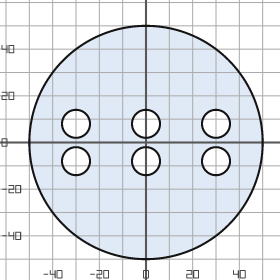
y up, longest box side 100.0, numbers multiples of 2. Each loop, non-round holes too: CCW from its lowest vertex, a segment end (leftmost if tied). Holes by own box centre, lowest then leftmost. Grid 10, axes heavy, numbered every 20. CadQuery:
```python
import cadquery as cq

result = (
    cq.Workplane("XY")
    .moveTo(0.0, 0.0)
    .circle(50.0)
    .moveTo(-30.0, -8.0)
    .circle(6.0)
    .moveTo(0.0, -8.0)
    .circle(6.0)
    .moveTo(30.0, -8.0)
    .circle(6.0)
    .moveTo(-30.0, 8.0)
    .circle(6.0)
    .moveTo(0.0, 8.0)
    .circle(6.0)
    .moveTo(30.0, 8.0)
    .circle(6.0)
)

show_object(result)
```